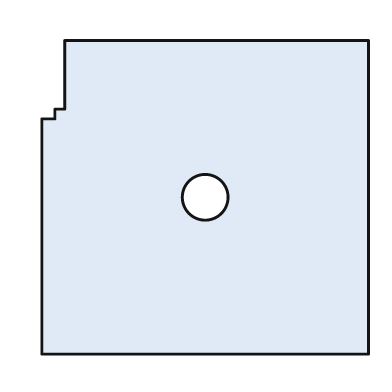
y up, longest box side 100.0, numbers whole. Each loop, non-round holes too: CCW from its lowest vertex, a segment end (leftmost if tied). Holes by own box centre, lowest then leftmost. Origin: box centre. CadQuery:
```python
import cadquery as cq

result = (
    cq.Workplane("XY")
    .moveTo(-50.0, -48.0)
    .lineTo(50.0, -48.0)
    .lineTo(50.0, 48.0)
    .lineTo(-43.0, 48.0)
    .lineTo(-43.0, 27.0)
    .lineTo(-46.0, 27.0)
    .lineTo(-46.0, 24.0)
    .lineTo(-50.0, 24.0)
    .close()
    .moveTo(0.0, 0.0)
    .circle(7.0)
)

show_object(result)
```